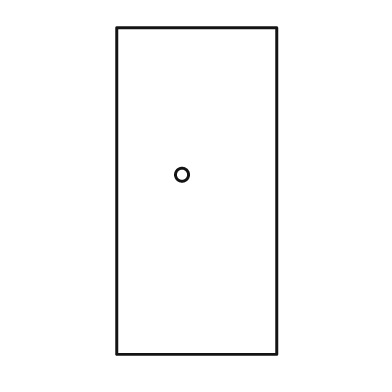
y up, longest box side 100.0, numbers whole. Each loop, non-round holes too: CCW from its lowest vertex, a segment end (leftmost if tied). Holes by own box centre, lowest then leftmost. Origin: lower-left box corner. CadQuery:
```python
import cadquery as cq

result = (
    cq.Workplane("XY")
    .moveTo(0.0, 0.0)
    .lineTo(49.0, 0.0)
    .lineTo(49.0, 100.0)
    .lineTo(0.0, 100.0)
    .close()
    .moveTo(20.0, 55.0)
    .circle(2.0)
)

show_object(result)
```